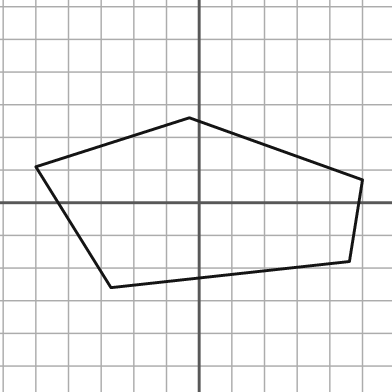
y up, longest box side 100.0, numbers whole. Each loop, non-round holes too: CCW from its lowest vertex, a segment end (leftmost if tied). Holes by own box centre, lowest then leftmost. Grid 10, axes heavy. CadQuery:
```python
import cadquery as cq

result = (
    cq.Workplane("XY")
    .moveTo(-27.0, -26.0)
    .lineTo(46.0, -18.0)
    .lineTo(50.0, 7.0)
    .lineTo(-3.0, 26.0)
    .lineTo(-50.0, 11.0)
    .close()
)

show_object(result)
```